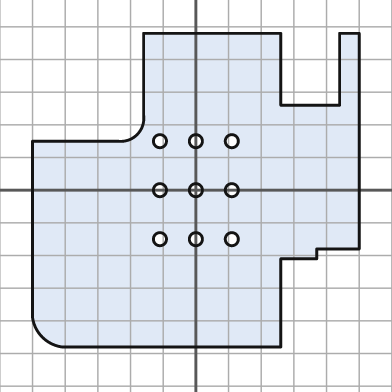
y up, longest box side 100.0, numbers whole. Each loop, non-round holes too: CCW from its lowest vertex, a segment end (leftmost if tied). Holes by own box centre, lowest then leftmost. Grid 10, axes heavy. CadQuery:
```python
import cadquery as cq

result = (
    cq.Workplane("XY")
    .moveTo(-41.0, -48.0)
    .lineTo(26.0, -48.0)
    .lineTo(26.0, -21.0)
    .lineTo(37.0, -21.0)
    .lineTo(37.0, -18.0)
    .lineTo(50.0, -18.0)
    .lineTo(50.0, 48.0)
    .lineTo(44.0, 48.0)
    .lineTo(44.0, 26.0)
    .lineTo(26.0, 26.0)
    .lineTo(26.0, 48.0)
    .lineTo(-16.0, 48.0)
    .lineTo(-16.0, 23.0)
    .threePointArc((-18.0, 17.0), (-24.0, 15.0))
    .lineTo(-50.0, 15.0)
    .lineTo(-50.0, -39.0)
    .threePointArc((-47.0, -45.0), (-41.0, -48.0))
    .close()
    .moveTo(-11.0, -15.0)
    .circle(2.0)
    .moveTo(0.0, -15.0)
    .circle(2.0)
    .moveTo(11.0, -15.0)
    .circle(2.0)
    .moveTo(-11.0, 0.0)
    .circle(2.0)
    .moveTo(0.0, 0.0)
    .circle(2.0)
    .moveTo(11.0, 0.0)
    .circle(2.0)
    .moveTo(-11.0, 15.0)
    .circle(2.0)
    .moveTo(0.0, 15.0)
    .circle(2.0)
    .moveTo(11.0, 15.0)
    .circle(2.0)
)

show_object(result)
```